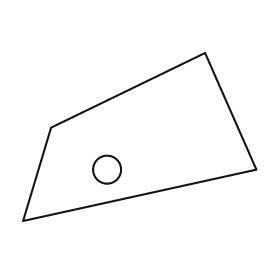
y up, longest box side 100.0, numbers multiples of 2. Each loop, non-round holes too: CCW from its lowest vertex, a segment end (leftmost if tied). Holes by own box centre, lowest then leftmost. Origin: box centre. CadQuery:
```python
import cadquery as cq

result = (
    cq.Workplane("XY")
    .moveTo(-50.0, -36.0)
    .lineTo(50.0, -14.0)
    .lineTo(28.0, 36.0)
    .lineTo(-38.0, 4.0)
    .close()
    .moveTo(-14.0, -14.0)
    .circle(6.0)
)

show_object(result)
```